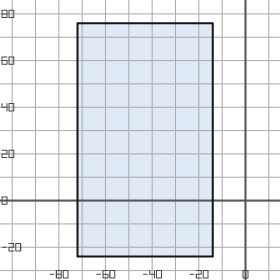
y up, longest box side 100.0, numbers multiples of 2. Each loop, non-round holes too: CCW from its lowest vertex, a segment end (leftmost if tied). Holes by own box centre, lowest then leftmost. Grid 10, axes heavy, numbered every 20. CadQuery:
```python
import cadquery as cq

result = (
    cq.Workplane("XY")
    .moveTo(-72.0, -24.0)
    .lineTo(-14.0, -24.0)
    .lineTo(-14.0, 76.0)
    .lineTo(-72.0, 76.0)
    .close()
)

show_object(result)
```